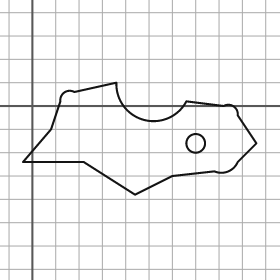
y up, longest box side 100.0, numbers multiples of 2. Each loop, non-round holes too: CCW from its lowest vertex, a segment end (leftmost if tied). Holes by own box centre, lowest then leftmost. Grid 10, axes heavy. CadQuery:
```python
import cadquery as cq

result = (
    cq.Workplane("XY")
    .moveTo(44.0, -38.0)
    .lineTo(60.0, -30.0)
    .lineTo(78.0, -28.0)
    .threePointArc((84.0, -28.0), (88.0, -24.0))
    .lineTo(96.0, -16.0)
    .lineTo(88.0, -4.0)
    .threePointArc((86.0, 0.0), (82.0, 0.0))
    .lineTo(66.0, 2.0)
    .threePointArc((48.0, -6.0), (36.0, 10.0))
    .lineTo(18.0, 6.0)
    .threePointArc((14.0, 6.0), (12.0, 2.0))
    .lineTo(8.0, -10.0)
    .lineTo(-4.0, -24.0)
    .lineTo(22.0, -24.0)
    .close()
    .moveTo(70.0, -16.0)
    .circle(4.0)
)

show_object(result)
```